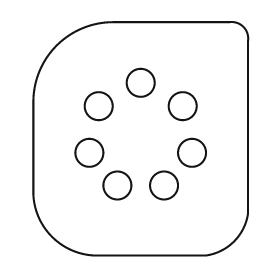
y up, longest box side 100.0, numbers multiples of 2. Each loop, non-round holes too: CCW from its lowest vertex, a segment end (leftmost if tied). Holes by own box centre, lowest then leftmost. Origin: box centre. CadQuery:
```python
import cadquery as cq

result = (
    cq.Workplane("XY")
    .moveTo(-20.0, -50.0)
    .lineTo(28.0, -50.0)
    .threePointArc((40.0, -44.0), (46.0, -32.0))
    .lineTo(46.0, 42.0)
    .threePointArc((44.0, 48.0), (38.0, 50.0))
    .lineTo(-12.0, 50.0)
    .threePointArc((-36.0, 40.0), (-46.0, 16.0))
    .lineTo(-46.0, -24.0)
    .threePointArc((-38.0, -42.0), (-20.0, -50.0))
    .close()
    .moveTo(-10.0, -20.0)
    .circle(6.0)
    .moveTo(10.0, -20.0)
    .circle(6.0)
    .moveTo(-22.0, -6.0)
    .circle(6.0)
    .moveTo(22.0, -6.0)
    .circle(6.0)
    .moveTo(-18.0, 14.0)
    .circle(6.0)
    .moveTo(18.0, 14.0)
    .circle(6.0)
    .moveTo(0.0, 24.0)
    .circle(6.0)
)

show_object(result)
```